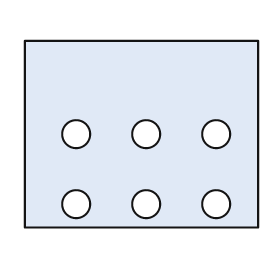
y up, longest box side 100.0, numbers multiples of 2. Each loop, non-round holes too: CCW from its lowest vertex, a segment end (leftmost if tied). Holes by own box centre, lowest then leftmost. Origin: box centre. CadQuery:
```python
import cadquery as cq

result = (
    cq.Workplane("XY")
    .moveTo(-50.0, -40.0)
    .lineTo(50.0, -40.0)
    .lineTo(50.0, 40.0)
    .lineTo(-50.0, 40.0)
    .close()
    .moveTo(-28.0, -30.0)
    .circle(6.0)
    .moveTo(2.0, -30.0)
    .circle(6.0)
    .moveTo(32.0, -30.0)
    .circle(6.0)
    .moveTo(-28.0, 0.0)
    .circle(6.0)
    .moveTo(2.0, 0.0)
    .circle(6.0)
    .moveTo(32.0, 0.0)
    .circle(6.0)
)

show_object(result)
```